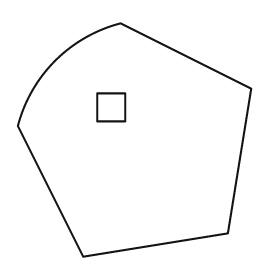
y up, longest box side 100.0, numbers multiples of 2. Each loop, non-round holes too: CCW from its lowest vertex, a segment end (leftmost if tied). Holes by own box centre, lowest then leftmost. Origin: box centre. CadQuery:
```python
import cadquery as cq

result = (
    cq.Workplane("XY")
    .moveTo(-22.0, -50.0)
    .lineTo(40.0, -40.0)
    .lineTo(50.0, 22.0)
    .lineTo(-6.0, 50.0)
    .threePointArc((-34.0, 34.0), (-50.0, 6.0))
    .close()
    .moveTo(-16.0, 8.0)
    .lineTo(-4.0, 8.0)
    .lineTo(-4.0, 20.0)
    .lineTo(-16.0, 20.0)
    .close()
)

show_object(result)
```